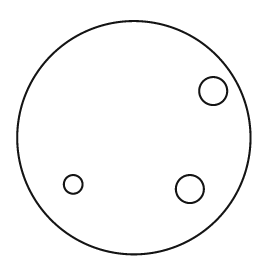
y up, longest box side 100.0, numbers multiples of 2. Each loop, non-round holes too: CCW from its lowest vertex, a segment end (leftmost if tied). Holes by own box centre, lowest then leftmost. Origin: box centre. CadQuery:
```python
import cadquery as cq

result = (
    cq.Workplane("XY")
    .moveTo(0.0, 0.0)
    .circle(50.0)
    .moveTo(24.0, -22.0)
    .circle(6.0)
    .moveTo(-26.0, -20.0)
    .circle(4.0)
    .moveTo(34.0, 20.0)
    .circle(6.0)
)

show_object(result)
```